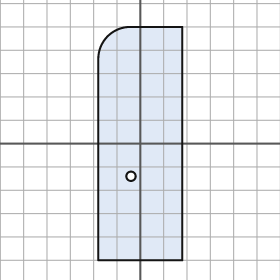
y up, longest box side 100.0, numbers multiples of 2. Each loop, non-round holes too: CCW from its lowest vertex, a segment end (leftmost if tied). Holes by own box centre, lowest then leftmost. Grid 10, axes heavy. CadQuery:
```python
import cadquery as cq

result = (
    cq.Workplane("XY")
    .moveTo(-18.0, -50.0)
    .lineTo(18.0, -50.0)
    .lineTo(18.0, 50.0)
    .lineTo(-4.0, 50.0)
    .threePointArc((-14.0, 46.0), (-18.0, 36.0))
    .close()
    .moveTo(-4.0, -14.0)
    .circle(2.0)
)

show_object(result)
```